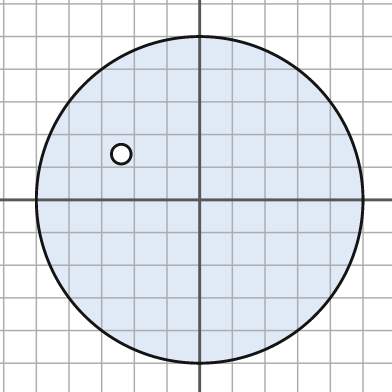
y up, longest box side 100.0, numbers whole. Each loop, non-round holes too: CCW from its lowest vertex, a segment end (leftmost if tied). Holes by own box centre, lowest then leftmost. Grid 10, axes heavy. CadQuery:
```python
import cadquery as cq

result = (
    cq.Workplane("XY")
    .moveTo(0.0, 0.0)
    .circle(50.0)
    .moveTo(-24.0, 14.0)
    .circle(3.0)
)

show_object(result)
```